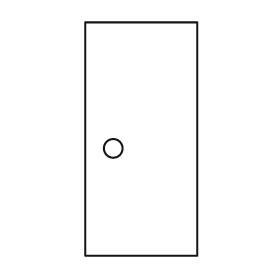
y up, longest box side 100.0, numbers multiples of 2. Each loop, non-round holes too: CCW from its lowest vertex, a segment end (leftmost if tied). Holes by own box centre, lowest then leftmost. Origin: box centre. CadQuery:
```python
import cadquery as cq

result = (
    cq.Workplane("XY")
    .moveTo(-24.0, -50.0)
    .lineTo(24.0, -50.0)
    .lineTo(24.0, 50.0)
    .lineTo(-24.0, 50.0)
    .close()
    .moveTo(-12.0, -4.0)
    .circle(4.0)
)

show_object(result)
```